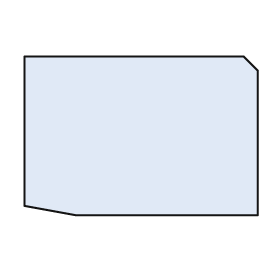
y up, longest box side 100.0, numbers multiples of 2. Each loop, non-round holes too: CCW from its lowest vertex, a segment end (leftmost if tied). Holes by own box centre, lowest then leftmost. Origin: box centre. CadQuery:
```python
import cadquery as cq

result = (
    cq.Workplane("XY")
    .moveTo(-28.0, -34.0)
    .lineTo(50.0, -34.0)
    .lineTo(50.0, 28.0)
    .lineTo(44.0, 34.0)
    .lineTo(-50.0, 34.0)
    .lineTo(-50.0, -30.0)
    .close()
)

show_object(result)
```